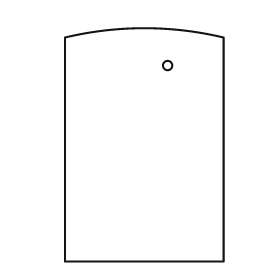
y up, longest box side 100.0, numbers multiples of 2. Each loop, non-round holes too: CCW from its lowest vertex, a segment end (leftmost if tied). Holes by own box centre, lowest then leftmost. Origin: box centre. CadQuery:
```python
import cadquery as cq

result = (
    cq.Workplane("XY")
    .moveTo(-34.0, -50.0)
    .lineTo(34.0, -50.0)
    .lineTo(34.0, 46.0)
    .threePointArc((0.0, 50.0), (-34.0, 46.0))
    .close()
    .moveTo(10.0, 34.0)
    .circle(2.0)
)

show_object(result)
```